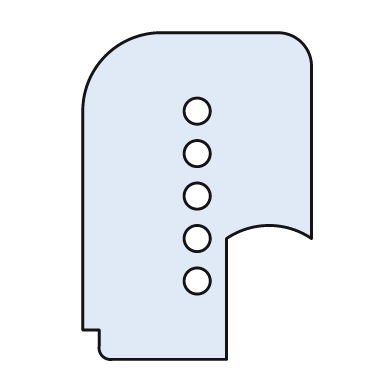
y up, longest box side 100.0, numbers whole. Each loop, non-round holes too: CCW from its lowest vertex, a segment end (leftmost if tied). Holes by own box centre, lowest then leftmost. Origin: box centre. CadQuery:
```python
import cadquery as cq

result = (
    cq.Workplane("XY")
    .moveTo(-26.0, -50.0)
    .lineTo(9.0, -50.0)
    .lineTo(9.0, -13.0)
    .threePointArc((22.0, -9.0), (35.0, -13.0))
    .lineTo(35.0, 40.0)
    .threePointArc((32.0, 47.0), (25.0, 50.0))
    .lineTo(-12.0, 50.0)
    .threePointArc((-28.0, 43.0), (-35.0, 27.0))
    .lineTo(-35.0, -41.0)
    .lineTo(-30.0, -41.0)
    .lineTo(-30.0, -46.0)
    .threePointArc((-29.0, -49.0), (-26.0, -50.0))
    .close()
    .moveTo(0.0, -26.0)
    .circle(4.0)
    .moveTo(0.0, -13.0)
    .circle(4.0)
    .moveTo(0.0, 0.0)
    .circle(4.0)
    .moveTo(0.0, 13.0)
    .circle(4.0)
    .moveTo(0.0, 26.0)
    .circle(4.0)
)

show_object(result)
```